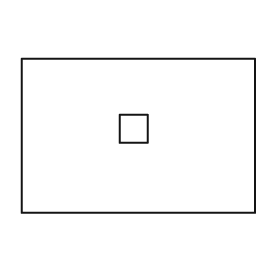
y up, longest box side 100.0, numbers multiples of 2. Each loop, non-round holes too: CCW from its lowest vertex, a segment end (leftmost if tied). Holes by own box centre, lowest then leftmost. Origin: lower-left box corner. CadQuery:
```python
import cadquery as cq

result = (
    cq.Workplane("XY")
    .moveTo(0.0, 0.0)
    .lineTo(100.0, 0.0)
    .lineTo(100.0, 66.0)
    .lineTo(0.0, 66.0)
    .close()
    .moveTo(42.0, 30.0)
    .lineTo(54.0, 30.0)
    .lineTo(54.0, 42.0)
    .lineTo(42.0, 42.0)
    .close()
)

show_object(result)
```